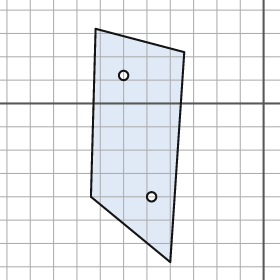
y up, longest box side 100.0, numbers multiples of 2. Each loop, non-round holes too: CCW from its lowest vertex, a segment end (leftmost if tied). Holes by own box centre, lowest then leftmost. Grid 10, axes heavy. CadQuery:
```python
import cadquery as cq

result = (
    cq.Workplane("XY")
    .moveTo(-40.0, -68.0)
    .lineTo(-34.0, 22.0)
    .lineTo(-72.0, 32.0)
    .lineTo(-74.0, -40.0)
    .close()
    .moveTo(-48.0, -40.0)
    .circle(2.0)
    .moveTo(-60.0, 12.0)
    .circle(2.0)
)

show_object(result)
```